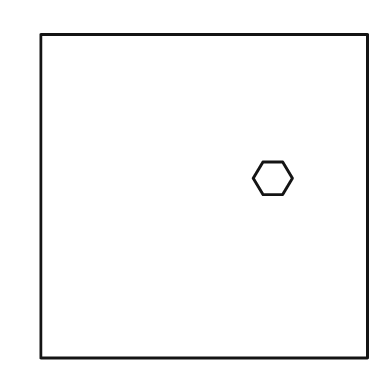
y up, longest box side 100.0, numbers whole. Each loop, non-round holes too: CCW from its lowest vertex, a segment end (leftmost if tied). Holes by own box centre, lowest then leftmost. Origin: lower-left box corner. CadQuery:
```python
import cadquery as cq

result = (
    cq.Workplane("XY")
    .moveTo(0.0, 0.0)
    .lineTo(100.0, 0.0)
    .lineTo(100.0, 99.0)
    .lineTo(0.0, 99.0)
    .close()
    .moveTo(68.0, 50.0)
    .lineTo(74.0, 50.0)
    .lineTo(77.0, 55.0)
    .lineTo(74.0, 60.0)
    .lineTo(68.0, 60.0)
    .lineTo(65.0, 55.0)
    .close()
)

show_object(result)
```